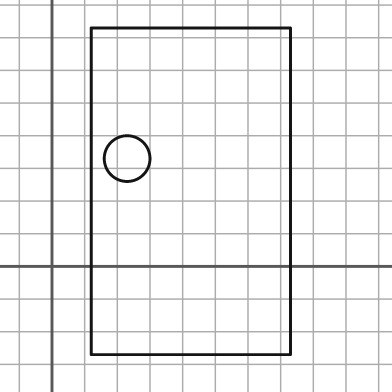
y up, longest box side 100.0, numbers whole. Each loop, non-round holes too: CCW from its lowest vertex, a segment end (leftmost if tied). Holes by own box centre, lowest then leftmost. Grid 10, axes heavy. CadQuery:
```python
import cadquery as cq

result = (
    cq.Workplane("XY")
    .moveTo(12.0, -27.0)
    .lineTo(73.0, -27.0)
    .lineTo(73.0, 73.0)
    .lineTo(12.0, 73.0)
    .close()
    .moveTo(23.0, 33.0)
    .circle(7.0)
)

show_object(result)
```